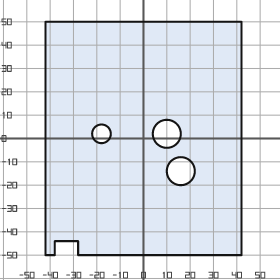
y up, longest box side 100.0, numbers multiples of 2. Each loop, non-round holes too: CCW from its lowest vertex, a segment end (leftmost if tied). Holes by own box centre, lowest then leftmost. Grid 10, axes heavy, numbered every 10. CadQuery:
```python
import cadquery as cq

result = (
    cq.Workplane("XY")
    .moveTo(-42.0, -50.0)
    .lineTo(-38.0, -50.0)
    .lineTo(-38.0, -44.0)
    .lineTo(-28.0, -44.0)
    .lineTo(-28.0, -50.0)
    .lineTo(42.0, -50.0)
    .lineTo(42.0, 50.0)
    .lineTo(-42.0, 50.0)
    .close()
    .moveTo(16.0, -14.0)
    .circle(6.0)
    .moveTo(-18.0, 2.0)
    .circle(4.0)
    .moveTo(10.0, 2.0)
    .circle(6.0)
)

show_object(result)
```